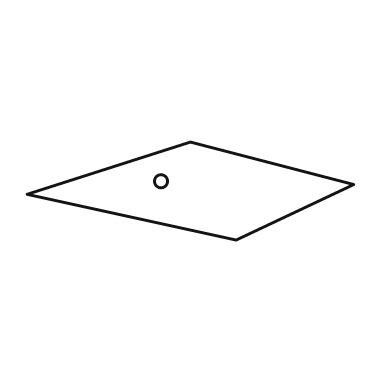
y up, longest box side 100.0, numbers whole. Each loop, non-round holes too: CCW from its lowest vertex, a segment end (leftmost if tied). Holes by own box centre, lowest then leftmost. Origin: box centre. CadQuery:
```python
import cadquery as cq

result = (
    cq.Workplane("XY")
    .moveTo(14.0, -15.0)
    .lineTo(50.0, 2.0)
    .lineTo(0.0, 15.0)
    .lineTo(-50.0, -1.0)
    .close()
    .moveTo(-9.0, 3.0)
    .circle(2.0)
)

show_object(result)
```